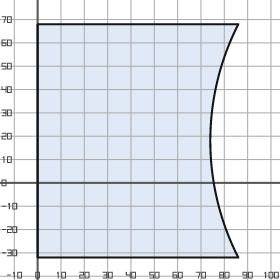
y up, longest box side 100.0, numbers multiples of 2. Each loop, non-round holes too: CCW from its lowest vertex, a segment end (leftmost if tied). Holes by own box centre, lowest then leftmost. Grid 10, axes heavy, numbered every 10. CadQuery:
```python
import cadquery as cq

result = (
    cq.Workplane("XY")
    .moveTo(0.0, -32.0)
    .lineTo(86.0, -32.0)
    .threePointArc((74.0, 18.0), (86.0, 68.0))
    .lineTo(0.0, 68.0)
    .close()
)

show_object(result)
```